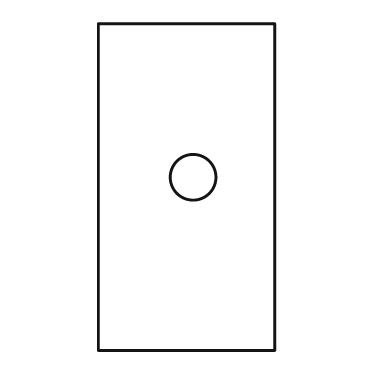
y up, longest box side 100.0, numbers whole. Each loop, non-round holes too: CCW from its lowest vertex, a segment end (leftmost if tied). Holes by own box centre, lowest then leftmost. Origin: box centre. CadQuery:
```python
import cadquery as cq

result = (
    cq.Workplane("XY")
    .moveTo(-27.0, -50.0)
    .lineTo(27.0, -50.0)
    .lineTo(27.0, 50.0)
    .lineTo(-27.0, 50.0)
    .close()
    .moveTo(2.0, 3.0)
    .circle(7.0)
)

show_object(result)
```